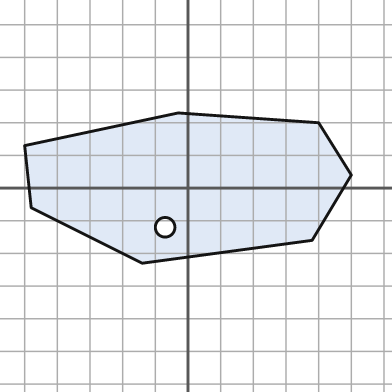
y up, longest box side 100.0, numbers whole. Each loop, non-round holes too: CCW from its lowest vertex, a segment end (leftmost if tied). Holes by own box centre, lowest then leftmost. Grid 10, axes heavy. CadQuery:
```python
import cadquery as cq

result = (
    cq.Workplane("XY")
    .moveTo(-14.0, -23.0)
    .lineTo(38.0, -16.0)
    .lineTo(50.0, 4.0)
    .lineTo(40.0, 20.0)
    .lineTo(-3.0, 23.0)
    .lineTo(-50.0, 13.0)
    .lineTo(-48.0, -6.0)
    .close()
    .moveTo(-7.0, -12.0)
    .circle(3.0)
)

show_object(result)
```